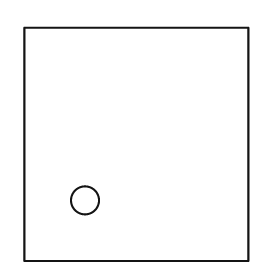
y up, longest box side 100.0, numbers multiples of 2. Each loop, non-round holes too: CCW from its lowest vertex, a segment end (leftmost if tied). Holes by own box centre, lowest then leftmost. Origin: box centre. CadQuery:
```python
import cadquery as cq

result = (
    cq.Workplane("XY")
    .moveTo(-48.0, -50.0)
    .lineTo(48.0, -50.0)
    .lineTo(48.0, 50.0)
    .lineTo(-48.0, 50.0)
    .close()
    .moveTo(-22.0, -24.0)
    .circle(6.0)
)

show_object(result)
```